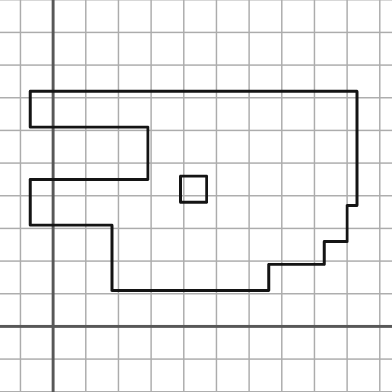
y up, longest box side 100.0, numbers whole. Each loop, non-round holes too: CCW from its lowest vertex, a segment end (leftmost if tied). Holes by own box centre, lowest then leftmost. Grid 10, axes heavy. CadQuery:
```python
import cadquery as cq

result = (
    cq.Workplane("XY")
    .moveTo(18.0, 11.0)
    .lineTo(66.0, 11.0)
    .lineTo(66.0, 19.0)
    .lineTo(83.0, 19.0)
    .lineTo(83.0, 26.0)
    .lineTo(90.0, 26.0)
    .lineTo(90.0, 37.0)
    .lineTo(93.0, 37.0)
    .lineTo(93.0, 72.0)
    .lineTo(-7.0, 72.0)
    .lineTo(-7.0, 61.0)
    .lineTo(29.0, 61.0)
    .lineTo(29.0, 45.0)
    .lineTo(-7.0, 45.0)
    .lineTo(-7.0, 31.0)
    .lineTo(18.0, 31.0)
    .close()
    .moveTo(39.0, 38.0)
    .lineTo(47.0, 38.0)
    .lineTo(47.0, 46.0)
    .lineTo(39.0, 46.0)
    .close()
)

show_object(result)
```